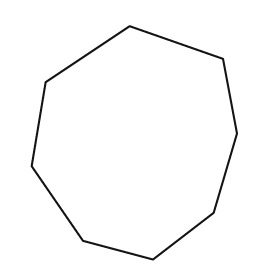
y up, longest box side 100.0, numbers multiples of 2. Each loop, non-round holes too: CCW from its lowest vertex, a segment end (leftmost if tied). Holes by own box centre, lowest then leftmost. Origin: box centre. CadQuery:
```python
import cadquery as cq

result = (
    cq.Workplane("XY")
    .moveTo(8.0, -50.0)
    .lineTo(34.0, -30.0)
    .lineTo(44.0, 4.0)
    .lineTo(38.0, 36.0)
    .lineTo(-2.0, 50.0)
    .lineTo(-38.0, 26.0)
    .lineTo(-44.0, -10.0)
    .lineTo(-22.0, -42.0)
    .close()
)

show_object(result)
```